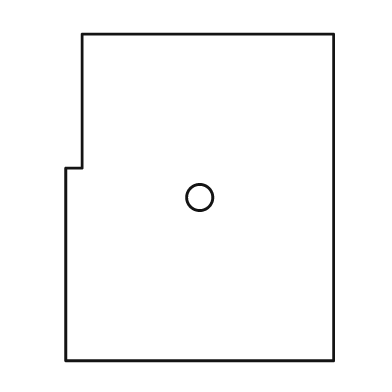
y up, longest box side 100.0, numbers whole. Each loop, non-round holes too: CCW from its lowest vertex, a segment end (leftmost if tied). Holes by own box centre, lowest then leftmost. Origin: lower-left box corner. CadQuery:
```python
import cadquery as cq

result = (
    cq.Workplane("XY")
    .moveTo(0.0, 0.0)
    .lineTo(82.0, 0.0)
    .lineTo(82.0, 100.0)
    .lineTo(5.0, 100.0)
    .lineTo(5.0, 59.0)
    .lineTo(0.0, 59.0)
    .close()
    .moveTo(41.0, 50.0)
    .circle(4.0)
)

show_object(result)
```